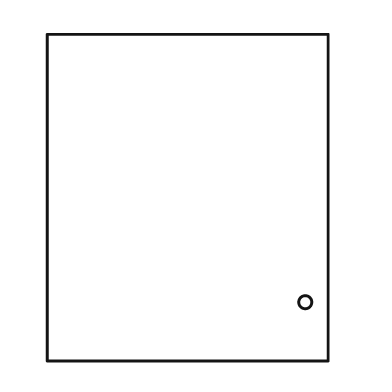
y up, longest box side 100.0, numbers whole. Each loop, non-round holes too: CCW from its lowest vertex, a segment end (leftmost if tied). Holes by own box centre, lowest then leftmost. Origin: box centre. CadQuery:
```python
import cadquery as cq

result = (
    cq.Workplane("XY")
    .moveTo(-43.0, -50.0)
    .lineTo(43.0, -50.0)
    .lineTo(43.0, 50.0)
    .lineTo(-43.0, 50.0)
    .close()
    .moveTo(36.0, -32.0)
    .circle(2.0)
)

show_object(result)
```